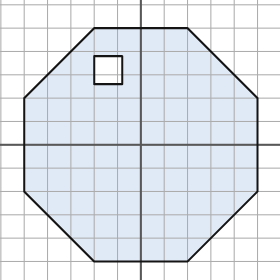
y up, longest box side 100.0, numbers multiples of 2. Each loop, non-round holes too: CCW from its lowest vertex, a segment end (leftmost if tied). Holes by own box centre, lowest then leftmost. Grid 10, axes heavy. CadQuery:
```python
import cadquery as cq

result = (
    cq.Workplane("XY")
    .moveTo(-20.0, -50.0)
    .lineTo(20.0, -50.0)
    .lineTo(50.0, -20.0)
    .lineTo(50.0, 20.0)
    .lineTo(20.0, 50.0)
    .lineTo(-20.0, 50.0)
    .lineTo(-50.0, 20.0)
    .lineTo(-50.0, -20.0)
    .close()
    .moveTo(-20.0, 26.0)
    .lineTo(-8.0, 26.0)
    .lineTo(-8.0, 38.0)
    .lineTo(-20.0, 38.0)
    .close()
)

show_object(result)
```